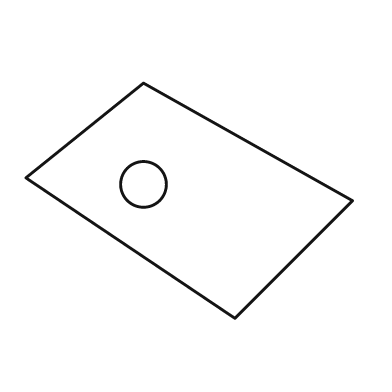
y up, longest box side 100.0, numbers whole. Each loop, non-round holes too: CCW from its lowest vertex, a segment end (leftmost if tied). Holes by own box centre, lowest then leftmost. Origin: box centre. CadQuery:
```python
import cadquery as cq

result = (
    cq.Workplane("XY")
    .moveTo(14.0, -36.0)
    .lineTo(50.0, 0.0)
    .lineTo(-14.0, 36.0)
    .lineTo(-50.0, 7.0)
    .close()
    .moveTo(-14.0, 5.0)
    .circle(7.0)
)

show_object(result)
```